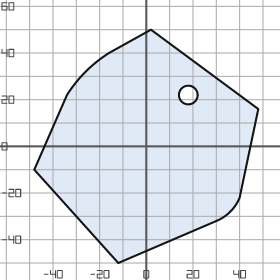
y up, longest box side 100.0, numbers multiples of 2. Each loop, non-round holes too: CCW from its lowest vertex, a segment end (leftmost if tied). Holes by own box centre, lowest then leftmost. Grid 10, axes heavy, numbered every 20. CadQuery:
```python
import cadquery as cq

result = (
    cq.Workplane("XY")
    .moveTo(-12.0, -50.0)
    .lineTo(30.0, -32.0)
    .threePointArc((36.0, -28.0), (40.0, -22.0))
    .lineTo(48.0, 16.0)
    .lineTo(2.0, 50.0)
    .lineTo(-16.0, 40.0)
    .threePointArc((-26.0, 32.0), (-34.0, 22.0))
    .lineTo(-48.0, -10.0)
    .close()
    .moveTo(18.0, 22.0)
    .circle(4.0)
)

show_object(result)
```